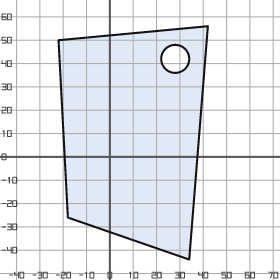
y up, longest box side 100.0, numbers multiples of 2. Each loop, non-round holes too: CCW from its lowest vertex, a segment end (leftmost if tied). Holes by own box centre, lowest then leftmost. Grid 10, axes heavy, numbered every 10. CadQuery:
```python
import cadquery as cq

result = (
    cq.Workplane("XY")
    .moveTo(34.0, -44.0)
    .lineTo(42.0, 56.0)
    .lineTo(-22.0, 50.0)
    .lineTo(-18.0, -26.0)
    .close()
    .moveTo(28.0, 42.0)
    .circle(6.0)
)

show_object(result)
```